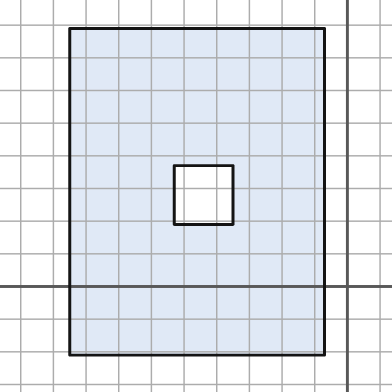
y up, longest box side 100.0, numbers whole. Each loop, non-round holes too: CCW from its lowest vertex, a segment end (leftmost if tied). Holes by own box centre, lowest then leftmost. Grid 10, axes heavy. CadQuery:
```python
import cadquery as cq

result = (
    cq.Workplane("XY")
    .moveTo(-85.0, -21.0)
    .lineTo(-7.0, -21.0)
    .lineTo(-7.0, 79.0)
    .lineTo(-85.0, 79.0)
    .close()
    .moveTo(-53.0, 19.0)
    .lineTo(-35.0, 19.0)
    .lineTo(-35.0, 37.0)
    .lineTo(-53.0, 37.0)
    .close()
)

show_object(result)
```